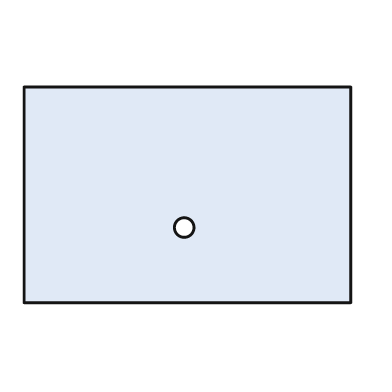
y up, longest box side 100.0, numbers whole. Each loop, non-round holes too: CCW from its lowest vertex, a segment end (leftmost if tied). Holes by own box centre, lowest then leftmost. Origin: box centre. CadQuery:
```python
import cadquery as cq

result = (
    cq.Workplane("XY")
    .moveTo(-50.0, -33.0)
    .lineTo(50.0, -33.0)
    .lineTo(50.0, 33.0)
    .lineTo(-50.0, 33.0)
    .close()
    .moveTo(-1.0, -10.0)
    .circle(3.0)
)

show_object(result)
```